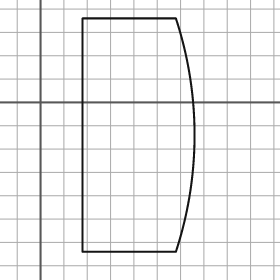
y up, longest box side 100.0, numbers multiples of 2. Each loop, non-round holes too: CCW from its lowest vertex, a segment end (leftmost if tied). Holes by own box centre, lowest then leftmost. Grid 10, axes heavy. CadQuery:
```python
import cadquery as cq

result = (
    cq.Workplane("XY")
    .moveTo(18.0, -64.0)
    .lineTo(58.0, -64.0)
    .threePointArc((66.0, -14.0), (58.0, 36.0))
    .lineTo(18.0, 36.0)
    .close()
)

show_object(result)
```